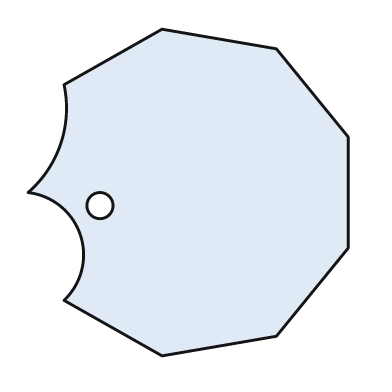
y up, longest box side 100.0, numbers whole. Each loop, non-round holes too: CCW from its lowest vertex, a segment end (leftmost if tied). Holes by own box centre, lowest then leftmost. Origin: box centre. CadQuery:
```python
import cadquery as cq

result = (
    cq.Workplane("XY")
    .moveTo(-8.0, -50.0)
    .lineTo(27.0, -44.0)
    .lineTo(49.0, -17.0)
    .lineTo(49.0, 17.0)
    .lineTo(27.0, 44.0)
    .lineTo(-8.0, 50.0)
    .lineTo(-38.0, 33.0)
    .threePointArc((-39.0, 15.0), (-49.0, 0.0))
    .threePointArc((-33.0, -13.0), (-38.0, -33.0))
    .close()
    .moveTo(-27.0, -4.0)
    .circle(4.0)
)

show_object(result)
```